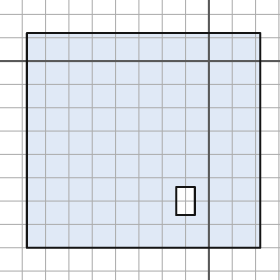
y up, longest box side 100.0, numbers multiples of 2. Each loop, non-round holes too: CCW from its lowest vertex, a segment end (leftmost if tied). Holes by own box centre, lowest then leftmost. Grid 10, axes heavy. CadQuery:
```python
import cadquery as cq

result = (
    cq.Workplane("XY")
    .moveTo(-78.0, -80.0)
    .lineTo(22.0, -80.0)
    .lineTo(22.0, 12.0)
    .lineTo(-78.0, 12.0)
    .close()
    .moveTo(-14.0, -66.0)
    .lineTo(-6.0, -66.0)
    .lineTo(-6.0, -54.0)
    .lineTo(-14.0, -54.0)
    .close()
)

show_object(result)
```